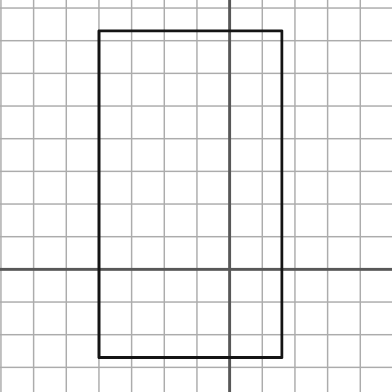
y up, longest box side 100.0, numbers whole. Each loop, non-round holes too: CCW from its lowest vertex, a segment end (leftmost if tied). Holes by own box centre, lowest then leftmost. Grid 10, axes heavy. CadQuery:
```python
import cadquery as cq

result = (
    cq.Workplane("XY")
    .moveTo(-40.0, -27.0)
    .lineTo(16.0, -27.0)
    .lineTo(16.0, 73.0)
    .lineTo(-40.0, 73.0)
    .close()
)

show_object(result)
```